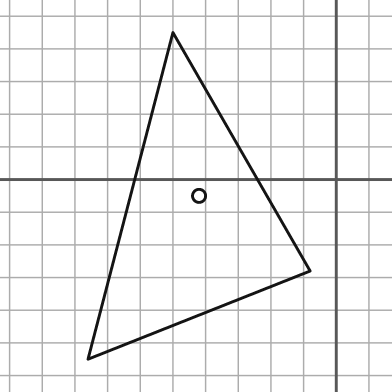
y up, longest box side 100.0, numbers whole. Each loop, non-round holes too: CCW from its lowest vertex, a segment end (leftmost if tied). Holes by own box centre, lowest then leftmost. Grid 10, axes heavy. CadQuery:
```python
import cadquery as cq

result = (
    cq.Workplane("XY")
    .moveTo(-76.0, -55.0)
    .lineTo(-8.0, -28.0)
    .lineTo(-50.0, 45.0)
    .close()
    .moveTo(-42.0, -5.0)
    .circle(2.0)
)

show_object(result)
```